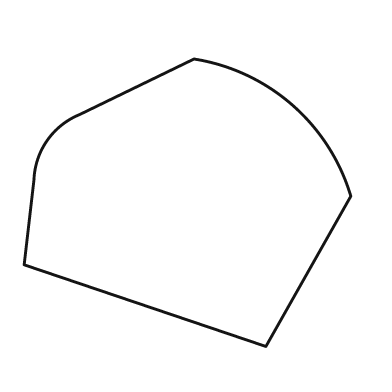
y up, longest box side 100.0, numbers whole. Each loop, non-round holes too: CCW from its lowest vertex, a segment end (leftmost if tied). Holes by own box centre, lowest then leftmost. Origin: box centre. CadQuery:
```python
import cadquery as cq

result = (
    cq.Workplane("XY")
    .moveTo(24.0, -44.0)
    .lineTo(50.0, 2.0)
    .threePointArc((32.0, 30.0), (2.0, 44.0))
    .lineTo(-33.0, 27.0)
    .threePointArc((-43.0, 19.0), (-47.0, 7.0))
    .lineTo(-50.0, -19.0)
    .close()
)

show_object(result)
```